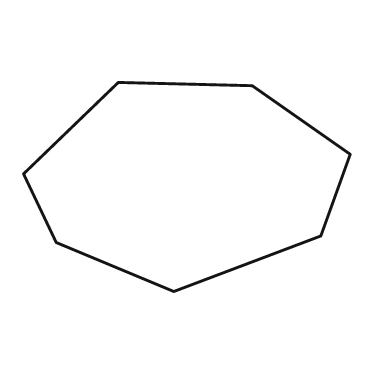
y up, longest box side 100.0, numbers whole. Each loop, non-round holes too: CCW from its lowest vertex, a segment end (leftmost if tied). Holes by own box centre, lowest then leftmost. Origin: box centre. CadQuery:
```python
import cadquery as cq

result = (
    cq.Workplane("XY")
    .moveTo(-4.0, -32.0)
    .lineTo(41.0, -15.0)
    .lineTo(50.0, 10.0)
    .lineTo(20.0, 31.0)
    .lineTo(-21.0, 32.0)
    .lineTo(-50.0, 4.0)
    .lineTo(-40.0, -17.0)
    .close()
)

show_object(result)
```